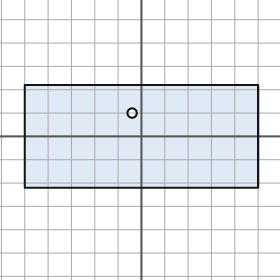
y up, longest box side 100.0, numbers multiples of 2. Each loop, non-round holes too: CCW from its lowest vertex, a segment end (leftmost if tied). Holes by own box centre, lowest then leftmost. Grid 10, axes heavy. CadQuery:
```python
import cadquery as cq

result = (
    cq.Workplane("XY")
    .moveTo(-50.0, -22.0)
    .lineTo(50.0, -22.0)
    .lineTo(50.0, 22.0)
    .lineTo(-50.0, 22.0)
    .close()
    .moveTo(-4.0, 10.0)
    .circle(2.0)
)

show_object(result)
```